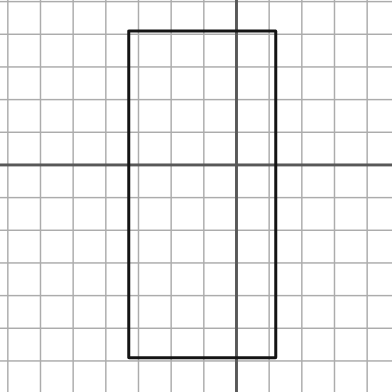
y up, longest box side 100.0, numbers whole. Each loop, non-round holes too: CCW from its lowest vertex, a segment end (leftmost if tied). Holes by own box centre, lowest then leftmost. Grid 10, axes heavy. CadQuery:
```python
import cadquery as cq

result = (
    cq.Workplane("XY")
    .moveTo(-33.0, -59.0)
    .lineTo(12.0, -59.0)
    .lineTo(12.0, 41.0)
    .lineTo(-33.0, 41.0)
    .close()
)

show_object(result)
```